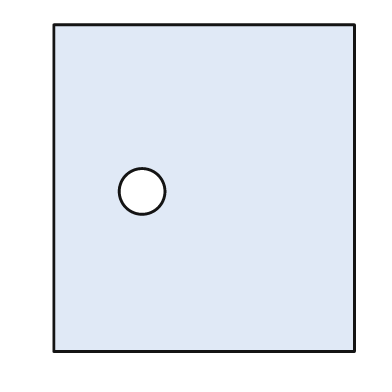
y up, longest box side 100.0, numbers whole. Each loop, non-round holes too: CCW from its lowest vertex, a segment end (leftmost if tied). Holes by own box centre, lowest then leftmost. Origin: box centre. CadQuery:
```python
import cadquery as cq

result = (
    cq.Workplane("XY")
    .moveTo(-46.0, -50.0)
    .lineTo(46.0, -50.0)
    .lineTo(46.0, 50.0)
    .lineTo(-46.0, 50.0)
    .close()
    .moveTo(-19.0, -1.0)
    .circle(7.0)
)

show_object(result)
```